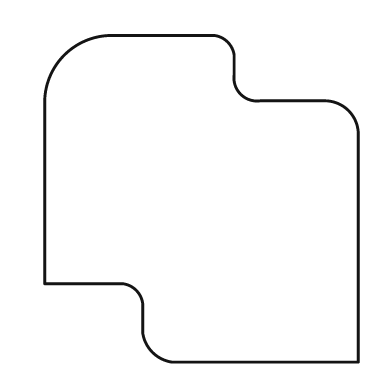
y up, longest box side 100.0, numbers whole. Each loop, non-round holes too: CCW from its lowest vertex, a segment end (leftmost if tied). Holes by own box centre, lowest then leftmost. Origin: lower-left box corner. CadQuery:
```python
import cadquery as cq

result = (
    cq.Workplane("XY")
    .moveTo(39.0, 0.0)
    .lineTo(96.0, 0.0)
    .lineTo(96.0, 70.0)
    .threePointArc((93.0, 77.0), (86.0, 80.0))
    .lineTo(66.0, 80.0)
    .threePointArc((60.0, 82.0), (58.0, 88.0))
    .lineTo(58.0, 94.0)
    .threePointArc((56.0, 98.0), (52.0, 100.0))
    .lineTo(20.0, 100.0)
    .threePointArc((6.0, 94.0), (0.0, 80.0))
    .lineTo(0.0, 24.0)
    .lineTo(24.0, 24.0)
    .threePointArc((28.0, 22.0), (30.0, 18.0))
    .lineTo(30.0, 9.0)
    .threePointArc((33.0, 3.0), (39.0, 0.0))
    .close()
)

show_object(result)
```